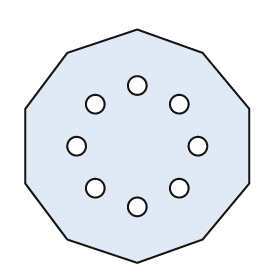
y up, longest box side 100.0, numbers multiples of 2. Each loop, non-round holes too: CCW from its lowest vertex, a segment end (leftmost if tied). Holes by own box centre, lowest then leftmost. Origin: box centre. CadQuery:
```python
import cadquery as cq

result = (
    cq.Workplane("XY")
    .moveTo(0.0, -50.0)
    .lineTo(28.0, -40.0)
    .lineTo(48.0, -16.0)
    .lineTo(48.0, 16.0)
    .lineTo(28.0, 40.0)
    .lineTo(0.0, 50.0)
    .lineTo(-30.0, 40.0)
    .lineTo(-48.0, 16.0)
    .lineTo(-48.0, -16.0)
    .lineTo(-30.0, -40.0)
    .close()
    .moveTo(0.0, -26.0)
    .circle(4.0)
    .moveTo(-18.0, -18.0)
    .circle(4.0)
    .moveTo(18.0, -18.0)
    .circle(4.0)
    .moveTo(-26.0, 0.0)
    .circle(4.0)
    .moveTo(26.0, 0.0)
    .circle(4.0)
    .moveTo(-18.0, 18.0)
    .circle(4.0)
    .moveTo(18.0, 18.0)
    .circle(4.0)
    .moveTo(0.0, 26.0)
    .circle(4.0)
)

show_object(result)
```